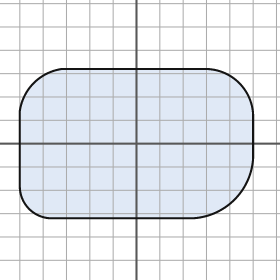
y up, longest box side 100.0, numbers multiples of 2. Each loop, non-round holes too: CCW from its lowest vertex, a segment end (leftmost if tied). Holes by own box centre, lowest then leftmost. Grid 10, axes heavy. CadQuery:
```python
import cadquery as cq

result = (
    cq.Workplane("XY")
    .moveTo(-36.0, -32.0)
    .lineTo(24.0, -32.0)
    .threePointArc((42.0, -24.0), (50.0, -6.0))
    .lineTo(50.0, 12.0)
    .threePointArc((44.0, 26.0), (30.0, 32.0))
    .lineTo(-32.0, 32.0)
    .threePointArc((-44.0, 26.0), (-50.0, 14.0))
    .lineTo(-50.0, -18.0)
    .threePointArc((-46.0, -28.0), (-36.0, -32.0))
    .close()
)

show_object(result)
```